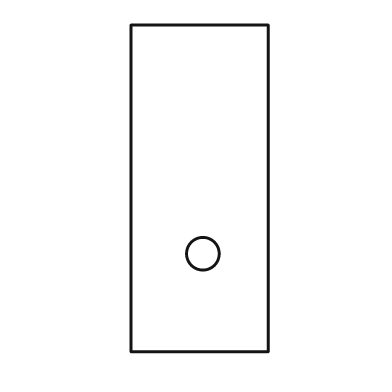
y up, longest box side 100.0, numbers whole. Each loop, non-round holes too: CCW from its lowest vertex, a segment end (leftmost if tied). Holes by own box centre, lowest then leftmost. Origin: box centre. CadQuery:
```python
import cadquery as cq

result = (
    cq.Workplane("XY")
    .moveTo(-21.0, -50.0)
    .lineTo(21.0, -50.0)
    .lineTo(21.0, 50.0)
    .lineTo(-21.0, 50.0)
    .close()
    .moveTo(1.0, -20.0)
    .circle(5.0)
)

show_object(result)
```